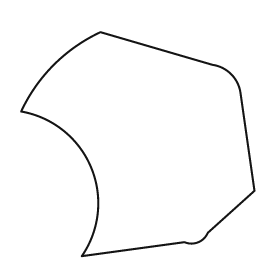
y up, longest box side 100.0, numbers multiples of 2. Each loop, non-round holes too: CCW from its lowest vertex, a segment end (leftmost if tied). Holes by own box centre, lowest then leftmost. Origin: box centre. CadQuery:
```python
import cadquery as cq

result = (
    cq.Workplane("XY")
    .moveTo(-24.0, -48.0)
    .lineTo(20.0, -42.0)
    .threePointArc((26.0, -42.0), (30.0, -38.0))
    .lineTo(50.0, -20.0)
    .lineTo(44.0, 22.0)
    .threePointArc((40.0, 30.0), (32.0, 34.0))
    .lineTo(-16.0, 48.0)
    .threePointArc((-36.0, 34.0), (-50.0, 14.0))
    .threePointArc((-20.0, -10.0), (-24.0, -48.0))
    .close()
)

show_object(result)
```